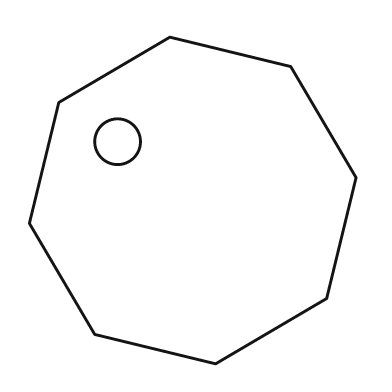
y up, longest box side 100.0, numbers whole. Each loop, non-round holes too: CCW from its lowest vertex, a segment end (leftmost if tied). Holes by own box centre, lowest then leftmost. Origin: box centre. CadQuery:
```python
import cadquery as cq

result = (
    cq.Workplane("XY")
    .moveTo(7.0, -50.0)
    .lineTo(41.0, -30.0)
    .lineTo(50.0, 7.0)
    .lineTo(30.0, 41.0)
    .lineTo(-7.0, 50.0)
    .lineTo(-41.0, 30.0)
    .lineTo(-50.0, -7.0)
    .lineTo(-30.0, -41.0)
    .close()
    .moveTo(-23.0, 18.0)
    .circle(7.0)
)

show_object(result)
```